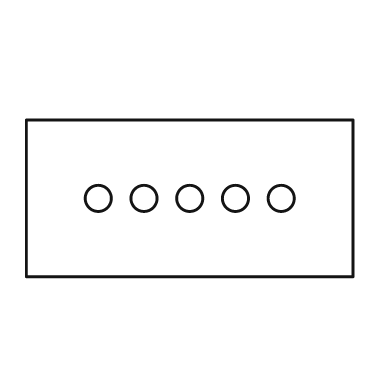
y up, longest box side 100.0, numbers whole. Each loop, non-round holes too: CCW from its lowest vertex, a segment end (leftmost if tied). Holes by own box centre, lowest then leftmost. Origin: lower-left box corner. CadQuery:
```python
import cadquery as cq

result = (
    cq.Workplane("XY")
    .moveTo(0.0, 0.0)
    .lineTo(100.0, 0.0)
    .lineTo(100.0, 48.0)
    .lineTo(0.0, 48.0)
    .close()
    .moveTo(22.0, 24.0)
    .circle(4.0)
    .moveTo(36.0, 24.0)
    .circle(4.0)
    .moveTo(50.0, 24.0)
    .circle(4.0)
    .moveTo(64.0, 24.0)
    .circle(4.0)
    .moveTo(78.0, 24.0)
    .circle(4.0)
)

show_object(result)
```